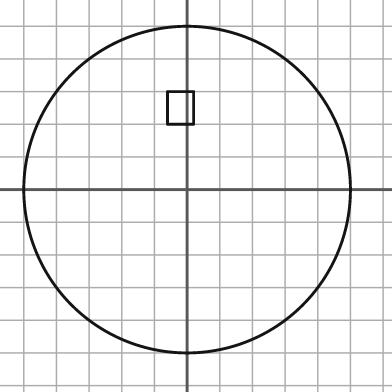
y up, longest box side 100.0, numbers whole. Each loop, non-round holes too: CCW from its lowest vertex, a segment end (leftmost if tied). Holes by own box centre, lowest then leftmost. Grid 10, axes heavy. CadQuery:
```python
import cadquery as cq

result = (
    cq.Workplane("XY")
    .moveTo(0.0, 0.0)
    .circle(50.0)
    .moveTo(-6.0, 20.0)
    .lineTo(2.0, 20.0)
    .lineTo(2.0, 30.0)
    .lineTo(-6.0, 30.0)
    .close()
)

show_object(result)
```